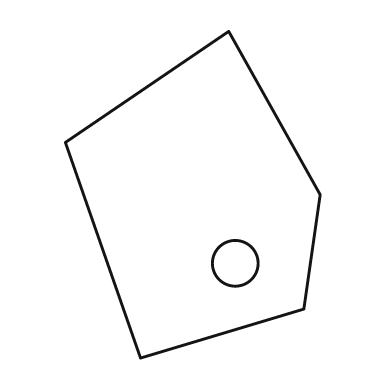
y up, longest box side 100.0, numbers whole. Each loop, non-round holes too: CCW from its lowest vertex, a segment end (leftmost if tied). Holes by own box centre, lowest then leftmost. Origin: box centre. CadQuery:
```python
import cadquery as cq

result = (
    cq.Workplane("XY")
    .moveTo(-16.0, -50.0)
    .lineTo(34.0, -35.0)
    .lineTo(39.0, 0.0)
    .lineTo(11.0, 50.0)
    .lineTo(-39.0, 16.0)
    .close()
    .moveTo(13.0, -21.0)
    .circle(7.0)
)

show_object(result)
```